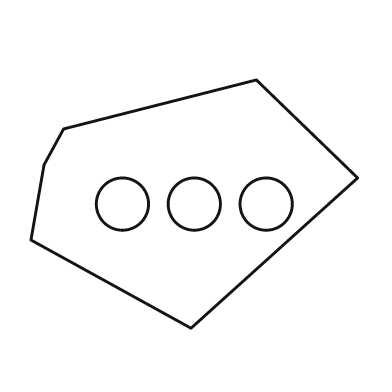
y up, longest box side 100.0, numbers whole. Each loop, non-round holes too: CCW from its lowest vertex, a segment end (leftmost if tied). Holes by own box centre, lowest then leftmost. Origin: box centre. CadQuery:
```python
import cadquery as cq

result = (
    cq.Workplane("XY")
    .moveTo(-1.0, -38.0)
    .lineTo(50.0, 8.0)
    .lineTo(19.0, 38.0)
    .lineTo(-40.0, 23.0)
    .lineTo(-46.0, 12.0)
    .lineTo(-50.0, -11.0)
    .close()
    .moveTo(-22.0, 0.0)
    .circle(8.0)
    .moveTo(0.0, 0.0)
    .circle(8.0)
    .moveTo(22.0, 0.0)
    .circle(8.0)
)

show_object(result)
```